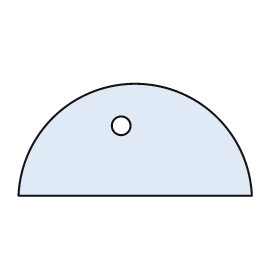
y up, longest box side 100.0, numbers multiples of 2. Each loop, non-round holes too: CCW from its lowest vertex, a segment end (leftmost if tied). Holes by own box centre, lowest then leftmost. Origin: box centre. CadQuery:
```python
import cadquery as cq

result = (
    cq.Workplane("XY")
    .moveTo(-50.0, -24.0)
    .lineTo(50.0, -24.0)
    .threePointArc((0.0, 24.0), (-50.0, -24.0))
    .close()
    .moveTo(-6.0, 6.0)
    .circle(4.0)
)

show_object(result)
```